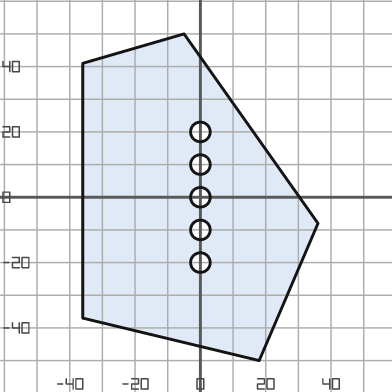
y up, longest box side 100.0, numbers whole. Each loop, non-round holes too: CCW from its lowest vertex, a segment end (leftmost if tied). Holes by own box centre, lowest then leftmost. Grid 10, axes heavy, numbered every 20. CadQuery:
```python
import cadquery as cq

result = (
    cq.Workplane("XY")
    .moveTo(18.0, -50.0)
    .lineTo(36.0, -8.0)
    .lineTo(-5.0, 50.0)
    .lineTo(-36.0, 41.0)
    .lineTo(-36.0, -37.0)
    .close()
    .moveTo(0.0, -20.0)
    .circle(3.0)
    .moveTo(0.0, -10.0)
    .circle(3.0)
    .moveTo(0.0, 0.0)
    .circle(3.0)
    .moveTo(0.0, 10.0)
    .circle(3.0)
    .moveTo(0.0, 20.0)
    .circle(3.0)
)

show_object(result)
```